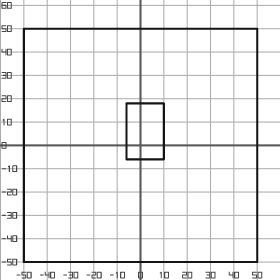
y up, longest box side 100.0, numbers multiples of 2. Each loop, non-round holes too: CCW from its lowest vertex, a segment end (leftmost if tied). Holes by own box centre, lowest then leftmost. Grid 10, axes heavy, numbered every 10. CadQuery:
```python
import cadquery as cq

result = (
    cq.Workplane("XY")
    .moveTo(-50.0, -50.0)
    .lineTo(50.0, -50.0)
    .lineTo(50.0, 50.0)
    .lineTo(-50.0, 50.0)
    .close()
    .moveTo(-6.0, -6.0)
    .lineTo(10.0, -6.0)
    .lineTo(10.0, 18.0)
    .lineTo(-6.0, 18.0)
    .close()
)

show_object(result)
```